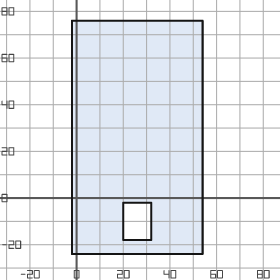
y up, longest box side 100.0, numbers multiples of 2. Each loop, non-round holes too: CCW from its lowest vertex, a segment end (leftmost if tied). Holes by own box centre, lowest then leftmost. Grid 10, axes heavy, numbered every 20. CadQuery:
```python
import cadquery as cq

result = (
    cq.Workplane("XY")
    .moveTo(-2.0, -24.0)
    .lineTo(54.0, -24.0)
    .lineTo(54.0, 76.0)
    .lineTo(-2.0, 76.0)
    .close()
    .moveTo(20.0, -18.0)
    .lineTo(32.0, -18.0)
    .lineTo(32.0, -2.0)
    .lineTo(20.0, -2.0)
    .close()
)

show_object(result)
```